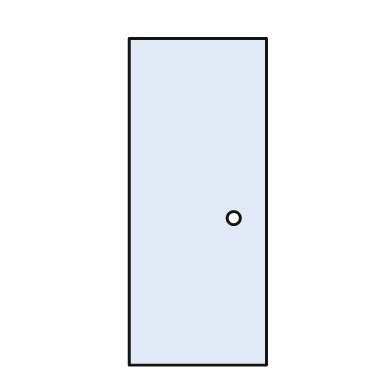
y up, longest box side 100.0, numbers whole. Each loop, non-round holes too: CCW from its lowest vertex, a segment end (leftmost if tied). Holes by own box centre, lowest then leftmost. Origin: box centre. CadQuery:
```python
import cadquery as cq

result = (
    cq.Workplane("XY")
    .moveTo(-21.0, -50.0)
    .lineTo(21.0, -50.0)
    .lineTo(21.0, 50.0)
    .lineTo(-21.0, 50.0)
    .close()
    .moveTo(11.0, -5.0)
    .circle(2.0)
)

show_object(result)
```